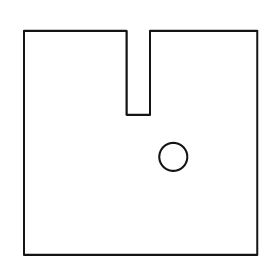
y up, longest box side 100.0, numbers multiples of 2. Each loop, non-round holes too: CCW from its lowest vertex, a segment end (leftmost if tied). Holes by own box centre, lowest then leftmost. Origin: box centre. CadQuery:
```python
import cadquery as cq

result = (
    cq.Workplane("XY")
    .moveTo(-50.0, -48.0)
    .lineTo(50.0, -48.0)
    .lineTo(50.0, 48.0)
    .lineTo(4.0, 48.0)
    .lineTo(4.0, 12.0)
    .lineTo(-6.0, 12.0)
    .lineTo(-6.0, 48.0)
    .lineTo(-50.0, 48.0)
    .close()
    .moveTo(14.0, -6.0)
    .circle(6.0)
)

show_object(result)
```